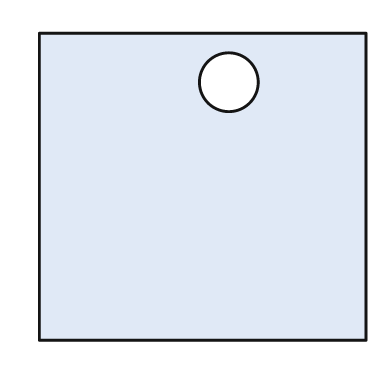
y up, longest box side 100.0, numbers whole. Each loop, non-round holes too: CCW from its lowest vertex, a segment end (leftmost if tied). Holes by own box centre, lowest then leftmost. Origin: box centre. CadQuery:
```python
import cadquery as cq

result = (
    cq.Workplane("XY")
    .moveTo(-50.0, -47.0)
    .lineTo(50.0, -47.0)
    .lineTo(50.0, 47.0)
    .lineTo(-50.0, 47.0)
    .close()
    .moveTo(8.0, 32.0)
    .circle(9.0)
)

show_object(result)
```